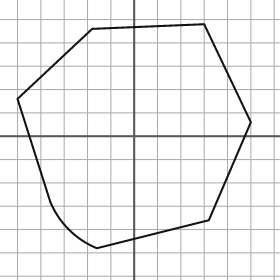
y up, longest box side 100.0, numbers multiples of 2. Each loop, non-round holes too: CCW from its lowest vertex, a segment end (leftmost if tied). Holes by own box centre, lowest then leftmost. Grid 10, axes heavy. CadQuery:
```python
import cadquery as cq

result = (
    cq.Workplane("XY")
    .moveTo(-16.0, -48.0)
    .lineTo(32.0, -36.0)
    .lineTo(50.0, 6.0)
    .lineTo(30.0, 48.0)
    .lineTo(-18.0, 46.0)
    .lineTo(-50.0, 16.0)
    .lineTo(-36.0, -28.0)
    .threePointArc((-28.0, -40.0), (-16.0, -48.0))
    .close()
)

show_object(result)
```